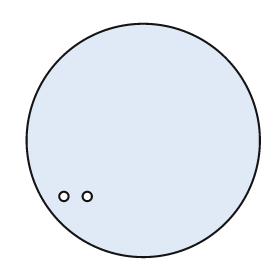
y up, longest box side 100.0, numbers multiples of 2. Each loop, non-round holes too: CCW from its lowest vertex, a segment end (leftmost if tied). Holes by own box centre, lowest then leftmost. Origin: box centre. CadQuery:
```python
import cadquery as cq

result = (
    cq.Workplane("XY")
    .moveTo(0.0, 0.0)
    .circle(50.0)
    .moveTo(-34.0, -24.0)
    .circle(2.0)
    .moveTo(-24.0, -24.0)
    .circle(2.0)
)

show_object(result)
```